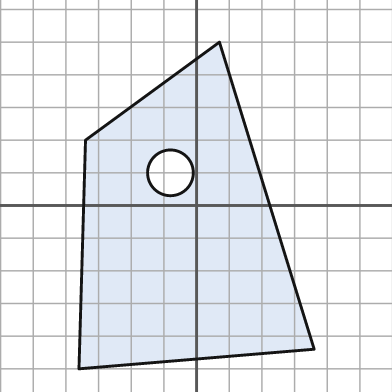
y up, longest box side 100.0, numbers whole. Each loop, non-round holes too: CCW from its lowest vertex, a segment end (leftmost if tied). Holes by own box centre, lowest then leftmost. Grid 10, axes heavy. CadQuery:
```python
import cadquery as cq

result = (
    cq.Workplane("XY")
    .moveTo(-36.0, -50.0)
    .lineTo(36.0, -44.0)
    .lineTo(7.0, 50.0)
    .lineTo(-34.0, 20.0)
    .close()
    .moveTo(-8.0, 10.0)
    .circle(7.0)
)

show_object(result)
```